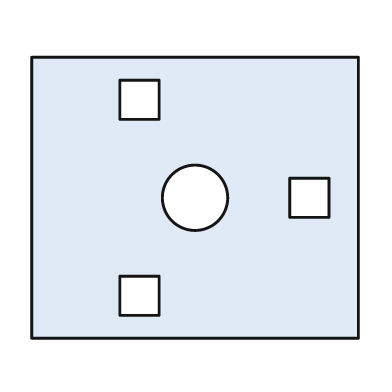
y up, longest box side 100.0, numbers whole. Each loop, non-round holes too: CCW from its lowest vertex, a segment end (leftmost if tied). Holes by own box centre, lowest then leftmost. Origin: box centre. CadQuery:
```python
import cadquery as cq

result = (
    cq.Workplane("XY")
    .moveTo(-50.0, -43.0)
    .lineTo(50.0, -43.0)
    .lineTo(50.0, 43.0)
    .lineTo(-50.0, 43.0)
    .close()
    .moveTo(-23.0, -36.0)
    .lineTo(-11.0, -36.0)
    .lineTo(-11.0, -24.0)
    .lineTo(-23.0, -24.0)
    .close()
    .moveTo(0.0, 0.0)
    .circle(10.0)
    .moveTo(29.0, -6.0)
    .lineTo(41.0, -6.0)
    .lineTo(41.0, 6.0)
    .lineTo(29.0, 6.0)
    .close()
    .moveTo(-23.0, 24.0)
    .lineTo(-11.0, 24.0)
    .lineTo(-11.0, 36.0)
    .lineTo(-23.0, 36.0)
    .close()
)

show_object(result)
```